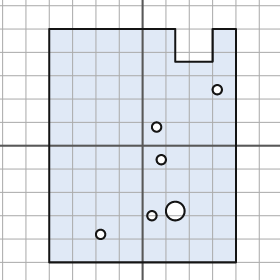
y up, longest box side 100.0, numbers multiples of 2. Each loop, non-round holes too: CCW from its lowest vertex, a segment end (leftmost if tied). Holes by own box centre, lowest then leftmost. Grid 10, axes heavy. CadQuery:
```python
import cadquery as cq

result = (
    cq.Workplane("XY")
    .moveTo(-40.0, -50.0)
    .lineTo(40.0, -50.0)
    .lineTo(40.0, 50.0)
    .lineTo(30.0, 50.0)
    .lineTo(30.0, 36.0)
    .lineTo(14.0, 36.0)
    .lineTo(14.0, 50.0)
    .lineTo(-40.0, 50.0)
    .close()
    .moveTo(-18.0, -38.0)
    .circle(2.0)
    .moveTo(4.0, -30.0)
    .circle(2.0)
    .moveTo(14.0, -28.0)
    .circle(4.0)
    .moveTo(8.0, -6.0)
    .circle(2.0)
    .moveTo(6.0, 8.0)
    .circle(2.0)
    .moveTo(32.0, 24.0)
    .circle(2.0)
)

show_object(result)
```